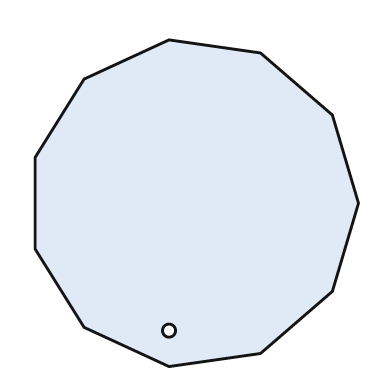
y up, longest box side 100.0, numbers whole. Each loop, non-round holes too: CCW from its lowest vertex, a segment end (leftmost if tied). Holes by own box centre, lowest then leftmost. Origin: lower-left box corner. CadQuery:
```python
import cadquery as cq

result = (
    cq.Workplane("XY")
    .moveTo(41.0, 0.0)
    .lineTo(69.0, 4.0)
    .lineTo(91.0, 23.0)
    .lineTo(99.0, 50.0)
    .lineTo(91.0, 77.0)
    .lineTo(69.0, 96.0)
    .lineTo(41.0, 100.0)
    .lineTo(15.0, 88.0)
    .lineTo(0.0, 64.0)
    .lineTo(0.0, 36.0)
    .lineTo(15.0, 12.0)
    .close()
    .moveTo(41.0, 11.0)
    .circle(2.0)
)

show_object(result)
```